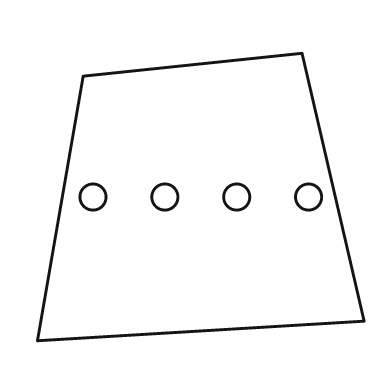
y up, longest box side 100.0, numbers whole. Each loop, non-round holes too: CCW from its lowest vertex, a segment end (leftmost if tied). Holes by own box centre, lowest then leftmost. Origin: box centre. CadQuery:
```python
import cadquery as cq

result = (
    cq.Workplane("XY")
    .moveTo(-50.0, -44.0)
    .lineTo(50.0, -38.0)
    .lineTo(31.0, 44.0)
    .lineTo(-36.0, 37.0)
    .close()
    .moveTo(-33.0, 0.0)
    .circle(4.0)
    .moveTo(-11.0, 0.0)
    .circle(4.0)
    .moveTo(11.0, 0.0)
    .circle(4.0)
    .moveTo(33.0, 0.0)
    .circle(4.0)
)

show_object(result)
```